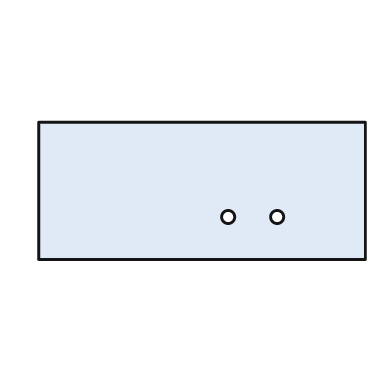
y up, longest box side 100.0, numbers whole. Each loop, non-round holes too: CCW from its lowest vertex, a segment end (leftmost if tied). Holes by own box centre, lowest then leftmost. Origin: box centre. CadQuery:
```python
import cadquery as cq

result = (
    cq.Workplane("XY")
    .moveTo(-50.0, -21.0)
    .lineTo(50.0, -21.0)
    .lineTo(50.0, 21.0)
    .lineTo(-50.0, 21.0)
    .close()
    .moveTo(8.0, -8.0)
    .circle(2.0)
    .moveTo(23.0, -8.0)
    .circle(2.0)
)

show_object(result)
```